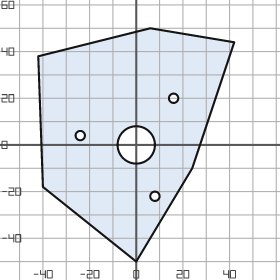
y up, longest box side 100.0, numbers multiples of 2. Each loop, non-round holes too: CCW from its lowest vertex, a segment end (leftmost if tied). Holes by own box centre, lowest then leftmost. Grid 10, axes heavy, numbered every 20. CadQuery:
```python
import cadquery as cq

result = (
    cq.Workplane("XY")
    .moveTo(0.0, -50.0)
    .lineTo(24.0, -10.0)
    .lineTo(42.0, 44.0)
    .lineTo(6.0, 50.0)
    .lineTo(-42.0, 38.0)
    .lineTo(-40.0, -18.0)
    .close()
    .moveTo(8.0, -22.0)
    .circle(2.0)
    .moveTo(0.0, 0.0)
    .circle(8.0)
    .moveTo(-24.0, 4.0)
    .circle(2.0)
    .moveTo(16.0, 20.0)
    .circle(2.0)
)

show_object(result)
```